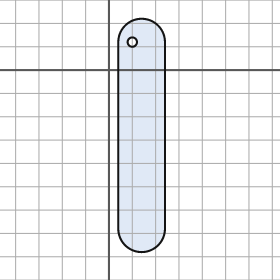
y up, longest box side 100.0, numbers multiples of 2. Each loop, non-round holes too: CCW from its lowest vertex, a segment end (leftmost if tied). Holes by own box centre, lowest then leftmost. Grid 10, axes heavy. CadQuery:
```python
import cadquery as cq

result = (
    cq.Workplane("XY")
    .moveTo(4.0, -68.0)
    .threePointArc((14.0, -78.0), (24.0, -68.0))
    .lineTo(24.0, 12.0)
    .threePointArc((14.0, 22.0), (4.0, 12.0))
    .close()
    .moveTo(10.0, 12.0)
    .circle(2.0)
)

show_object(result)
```